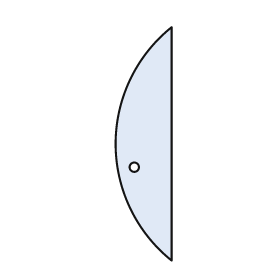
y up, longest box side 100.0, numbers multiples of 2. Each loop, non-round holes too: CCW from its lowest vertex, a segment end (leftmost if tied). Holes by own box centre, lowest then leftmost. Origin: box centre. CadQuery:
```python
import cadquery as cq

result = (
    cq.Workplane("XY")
    .moveTo(12.0, -50.0)
    .lineTo(12.0, 50.0)
    .threePointArc((-12.0, 0.0), (12.0, -50.0))
    .close()
    .moveTo(-4.0, -10.0)
    .circle(2.0)
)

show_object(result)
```